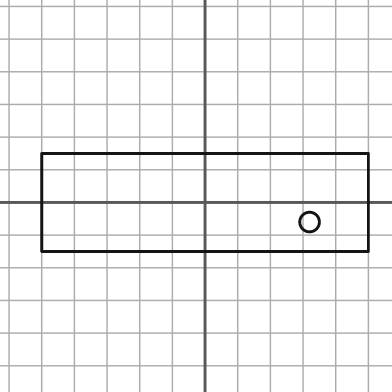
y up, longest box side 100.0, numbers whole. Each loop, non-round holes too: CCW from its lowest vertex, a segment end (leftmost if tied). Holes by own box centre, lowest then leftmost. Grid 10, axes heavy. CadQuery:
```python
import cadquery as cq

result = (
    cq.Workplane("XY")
    .moveTo(-50.0, -15.0)
    .lineTo(50.0, -15.0)
    .lineTo(50.0, 15.0)
    .lineTo(-50.0, 15.0)
    .close()
    .moveTo(32.0, -6.0)
    .circle(3.0)
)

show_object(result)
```